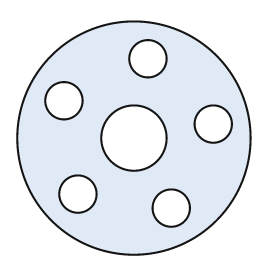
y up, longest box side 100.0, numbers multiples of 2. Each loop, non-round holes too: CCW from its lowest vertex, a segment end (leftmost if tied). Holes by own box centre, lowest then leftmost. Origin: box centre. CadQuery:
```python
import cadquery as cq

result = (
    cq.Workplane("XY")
    .moveTo(0.0, 0.0)
    .circle(50.0)
    .moveTo(16.0, -30.0)
    .circle(8.0)
    .moveTo(-24.0, -24.0)
    .circle(8.0)
    .moveTo(0.0, 0.0)
    .circle(14.0)
    .moveTo(34.0, 6.0)
    .circle(8.0)
    .moveTo(-30.0, 16.0)
    .circle(8.0)
    .moveTo(6.0, 34.0)
    .circle(8.0)
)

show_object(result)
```